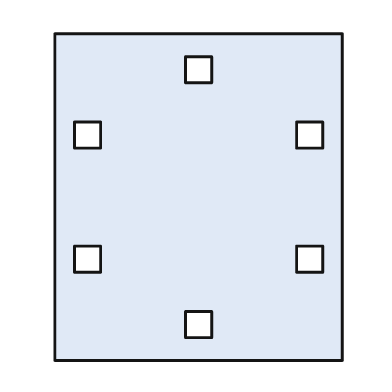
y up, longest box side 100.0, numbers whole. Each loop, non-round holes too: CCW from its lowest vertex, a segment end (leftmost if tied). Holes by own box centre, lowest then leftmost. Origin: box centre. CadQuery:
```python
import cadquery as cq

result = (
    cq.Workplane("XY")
    .moveTo(-44.0, -50.0)
    .lineTo(44.0, -50.0)
    .lineTo(44.0, 50.0)
    .lineTo(-44.0, 50.0)
    .close()
    .moveTo(-4.0, -43.0)
    .lineTo(4.0, -43.0)
    .lineTo(4.0, -35.0)
    .lineTo(-4.0, -35.0)
    .close()
    .moveTo(-38.0, -23.0)
    .lineTo(-30.0, -23.0)
    .lineTo(-30.0, -15.0)
    .lineTo(-38.0, -15.0)
    .close()
    .moveTo(30.0, -23.0)
    .lineTo(38.0, -23.0)
    .lineTo(38.0, -15.0)
    .lineTo(30.0, -15.0)
    .close()
    .moveTo(-38.0, 15.0)
    .lineTo(-30.0, 15.0)
    .lineTo(-30.0, 23.0)
    .lineTo(-38.0, 23.0)
    .close()
    .moveTo(30.0, 15.0)
    .lineTo(38.0, 15.0)
    .lineTo(38.0, 23.0)
    .lineTo(30.0, 23.0)
    .close()
    .moveTo(-4.0, 35.0)
    .lineTo(4.0, 35.0)
    .lineTo(4.0, 43.0)
    .lineTo(-4.0, 43.0)
    .close()
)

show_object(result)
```